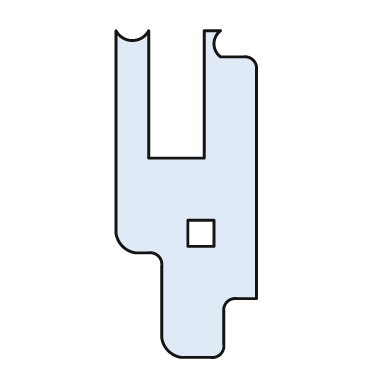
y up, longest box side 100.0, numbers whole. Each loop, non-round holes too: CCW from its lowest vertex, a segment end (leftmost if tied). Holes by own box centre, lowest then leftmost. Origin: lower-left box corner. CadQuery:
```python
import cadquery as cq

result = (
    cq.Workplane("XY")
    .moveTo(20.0, 0.0)
    .lineTo(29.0, 0.0)
    .threePointArc((32.0, 1.0), (33.0, 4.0))
    .lineTo(33.0, 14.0)
    .threePointArc((34.0, 17.0), (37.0, 18.0))
    .lineTo(43.0, 18.0)
    .lineTo(43.0, 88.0)
    .threePointArc((42.0, 91.0), (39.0, 92.0))
    .lineTo(32.0, 92.0)
    .threePointArc((30.0, 96.0), (32.0, 100.0))
    .lineTo(27.0, 100.0)
    .lineTo(27.0, 61.0)
    .lineTo(10.0, 61.0)
    .lineTo(10.0, 100.0)
    .threePointArc((5.0, 97.0), (0.0, 100.0))
    .lineTo(0.0, 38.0)
    .threePointArc((2.0, 34.0), (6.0, 32.0))
    .lineTo(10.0, 32.0)
    .threePointArc((13.0, 31.0), (14.0, 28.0))
    .lineTo(14.0, 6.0)
    .threePointArc((16.0, 2.0), (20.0, 0.0))
    .close()
    .moveTo(22.0, 34.0)
    .lineTo(30.0, 34.0)
    .lineTo(30.0, 42.0)
    .lineTo(22.0, 42.0)
    .close()
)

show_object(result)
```